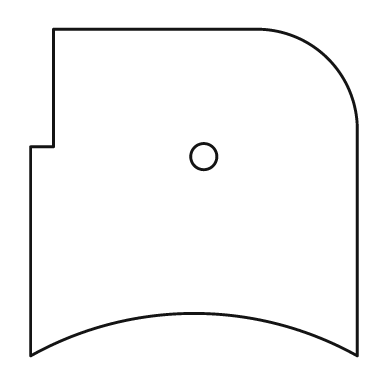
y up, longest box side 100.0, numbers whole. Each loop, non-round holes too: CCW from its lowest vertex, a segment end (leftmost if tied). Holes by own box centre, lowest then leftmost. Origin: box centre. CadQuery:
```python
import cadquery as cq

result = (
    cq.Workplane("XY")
    .moveTo(-50.0, -50.0)
    .threePointArc((0.0, -37.0), (50.0, -50.0))
    .lineTo(50.0, 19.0)
    .threePointArc((41.0, 41.0), (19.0, 50.0))
    .lineTo(-43.0, 50.0)
    .lineTo(-43.0, 14.0)
    .lineTo(-50.0, 14.0)
    .close()
    .moveTo(3.0, 11.0)
    .circle(4.0)
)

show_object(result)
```